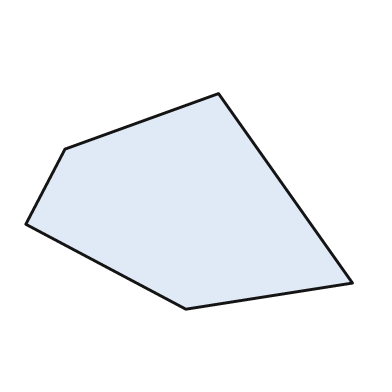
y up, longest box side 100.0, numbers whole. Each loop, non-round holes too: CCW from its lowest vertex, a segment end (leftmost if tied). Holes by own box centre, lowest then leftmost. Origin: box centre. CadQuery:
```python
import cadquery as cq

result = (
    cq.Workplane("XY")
    .moveTo(-1.0, -33.0)
    .lineTo(50.0, -25.0)
    .lineTo(9.0, 33.0)
    .lineTo(-38.0, 16.0)
    .lineTo(-50.0, -7.0)
    .close()
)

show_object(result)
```